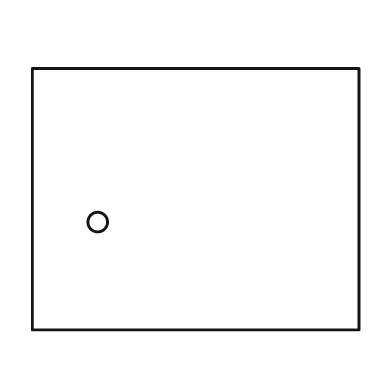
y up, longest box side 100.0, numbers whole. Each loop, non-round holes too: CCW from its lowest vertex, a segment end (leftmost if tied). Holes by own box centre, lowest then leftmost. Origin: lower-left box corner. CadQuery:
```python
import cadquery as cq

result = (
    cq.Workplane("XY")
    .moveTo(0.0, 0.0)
    .lineTo(100.0, 0.0)
    .lineTo(100.0, 80.0)
    .lineTo(0.0, 80.0)
    .close()
    .moveTo(20.0, 33.0)
    .circle(3.0)
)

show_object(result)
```